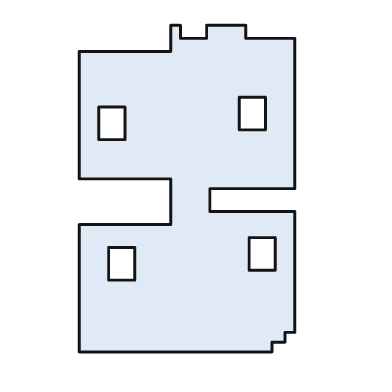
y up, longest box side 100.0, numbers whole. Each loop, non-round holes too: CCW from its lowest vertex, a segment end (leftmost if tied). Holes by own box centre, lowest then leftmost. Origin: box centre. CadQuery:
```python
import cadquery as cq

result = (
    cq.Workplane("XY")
    .moveTo(-33.0, -50.0)
    .lineTo(26.0, -50.0)
    .lineTo(26.0, -47.0)
    .lineTo(30.0, -47.0)
    .lineTo(30.0, -44.0)
    .lineTo(33.0, -44.0)
    .lineTo(33.0, -7.0)
    .lineTo(7.0, -7.0)
    .lineTo(7.0, 0.0)
    .lineTo(33.0, 0.0)
    .lineTo(33.0, 46.0)
    .lineTo(18.0, 46.0)
    .lineTo(18.0, 50.0)
    .lineTo(6.0, 50.0)
    .lineTo(6.0, 46.0)
    .lineTo(-2.0, 46.0)
    .lineTo(-2.0, 50.0)
    .lineTo(-5.0, 50.0)
    .lineTo(-5.0, 42.0)
    .lineTo(-33.0, 42.0)
    .lineTo(-33.0, 3.0)
    .lineTo(-5.0, 3.0)
    .lineTo(-5.0, -11.0)
    .lineTo(-33.0, -11.0)
    .close()
    .moveTo(-24.0, -28.0)
    .lineTo(-16.0, -28.0)
    .lineTo(-16.0, -18.0)
    .lineTo(-24.0, -18.0)
    .close()
    .moveTo(19.0, -25.0)
    .lineTo(27.0, -25.0)
    .lineTo(27.0, -15.0)
    .lineTo(19.0, -15.0)
    .close()
    .moveTo(-27.0, 15.0)
    .lineTo(-19.0, 15.0)
    .lineTo(-19.0, 25.0)
    .lineTo(-27.0, 25.0)
    .close()
    .moveTo(16.0, 18.0)
    .lineTo(24.0, 18.0)
    .lineTo(24.0, 28.0)
    .lineTo(16.0, 28.0)
    .close()
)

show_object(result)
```